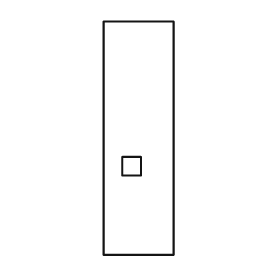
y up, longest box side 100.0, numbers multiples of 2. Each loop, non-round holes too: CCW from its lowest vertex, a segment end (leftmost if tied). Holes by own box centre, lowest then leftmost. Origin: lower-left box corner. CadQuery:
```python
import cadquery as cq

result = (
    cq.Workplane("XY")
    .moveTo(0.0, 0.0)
    .lineTo(30.0, 0.0)
    .lineTo(30.0, 100.0)
    .lineTo(0.0, 100.0)
    .close()
    .moveTo(8.0, 34.0)
    .lineTo(16.0, 34.0)
    .lineTo(16.0, 42.0)
    .lineTo(8.0, 42.0)
    .close()
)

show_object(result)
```